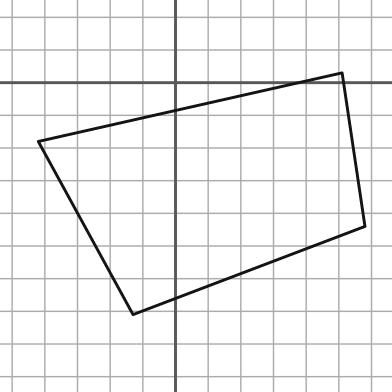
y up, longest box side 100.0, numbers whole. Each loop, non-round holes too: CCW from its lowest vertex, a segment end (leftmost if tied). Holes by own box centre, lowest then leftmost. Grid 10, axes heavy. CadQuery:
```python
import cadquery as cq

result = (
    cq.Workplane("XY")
    .moveTo(-13.0, -71.0)
    .lineTo(58.0, -44.0)
    .lineTo(51.0, 3.0)
    .lineTo(-42.0, -18.0)
    .close()
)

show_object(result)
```